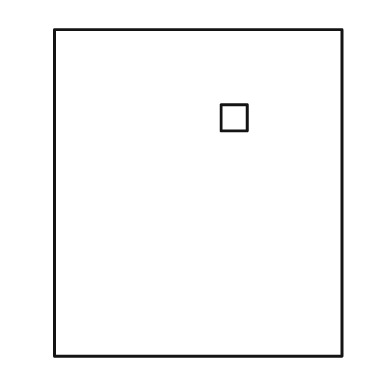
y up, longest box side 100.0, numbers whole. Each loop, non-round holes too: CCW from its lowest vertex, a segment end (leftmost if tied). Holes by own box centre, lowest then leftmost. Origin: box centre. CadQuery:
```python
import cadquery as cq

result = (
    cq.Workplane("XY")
    .moveTo(-44.0, -50.0)
    .lineTo(44.0, -50.0)
    .lineTo(44.0, 50.0)
    .lineTo(-44.0, 50.0)
    .close()
    .moveTo(7.0, 19.0)
    .lineTo(15.0, 19.0)
    .lineTo(15.0, 27.0)
    .lineTo(7.0, 27.0)
    .close()
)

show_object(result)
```